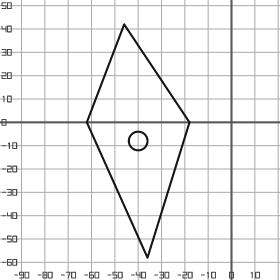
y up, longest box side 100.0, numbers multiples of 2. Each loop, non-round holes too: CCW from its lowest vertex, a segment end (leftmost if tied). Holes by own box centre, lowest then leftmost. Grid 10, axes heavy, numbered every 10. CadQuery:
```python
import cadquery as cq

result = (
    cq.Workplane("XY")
    .moveTo(-36.0, -58.0)
    .lineTo(-18.0, 0.0)
    .lineTo(-46.0, 42.0)
    .lineTo(-62.0, 0.0)
    .close()
    .moveTo(-40.0, -8.0)
    .circle(4.0)
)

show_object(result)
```